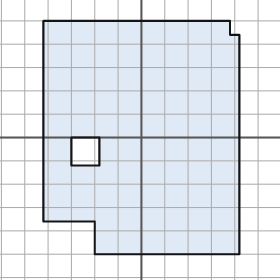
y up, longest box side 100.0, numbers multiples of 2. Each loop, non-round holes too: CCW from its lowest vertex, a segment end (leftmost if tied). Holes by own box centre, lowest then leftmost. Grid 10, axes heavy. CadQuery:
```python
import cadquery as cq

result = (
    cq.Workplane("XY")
    .moveTo(-20.0, -50.0)
    .lineTo(42.0, -50.0)
    .lineTo(42.0, 44.0)
    .lineTo(38.0, 44.0)
    .lineTo(38.0, 50.0)
    .lineTo(-42.0, 50.0)
    .lineTo(-42.0, -36.0)
    .lineTo(-20.0, -36.0)
    .close()
    .moveTo(-30.0, -12.0)
    .lineTo(-18.0, -12.0)
    .lineTo(-18.0, 0.0)
    .lineTo(-30.0, 0.0)
    .close()
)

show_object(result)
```